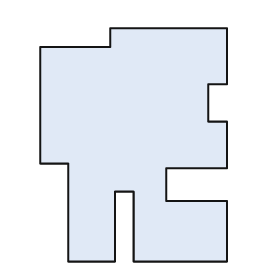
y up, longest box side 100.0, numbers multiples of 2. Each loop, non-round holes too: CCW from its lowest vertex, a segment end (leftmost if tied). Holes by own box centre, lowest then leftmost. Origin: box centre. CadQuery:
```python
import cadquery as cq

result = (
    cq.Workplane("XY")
    .moveTo(-28.0, -50.0)
    .lineTo(-8.0, -50.0)
    .lineTo(-8.0, -20.0)
    .lineTo(0.0, -20.0)
    .lineTo(0.0, -50.0)
    .lineTo(40.0, -50.0)
    .lineTo(40.0, -24.0)
    .lineTo(14.0, -24.0)
    .lineTo(14.0, -10.0)
    .lineTo(40.0, -10.0)
    .lineTo(40.0, 10.0)
    .lineTo(32.0, 10.0)
    .lineTo(32.0, 26.0)
    .lineTo(40.0, 26.0)
    .lineTo(40.0, 50.0)
    .lineTo(-10.0, 50.0)
    .lineTo(-10.0, 42.0)
    .lineTo(-40.0, 42.0)
    .lineTo(-40.0, -8.0)
    .lineTo(-28.0, -8.0)
    .close()
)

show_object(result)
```